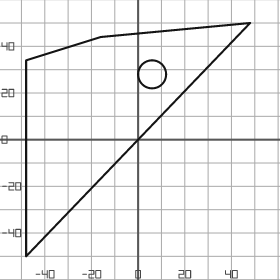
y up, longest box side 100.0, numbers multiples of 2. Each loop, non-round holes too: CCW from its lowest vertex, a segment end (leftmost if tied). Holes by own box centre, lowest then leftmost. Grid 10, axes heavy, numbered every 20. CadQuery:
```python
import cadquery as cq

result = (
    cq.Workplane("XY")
    .moveTo(-48.0, -50.0)
    .lineTo(48.0, 50.0)
    .lineTo(-16.0, 44.0)
    .lineTo(-48.0, 34.0)
    .close()
    .moveTo(6.0, 28.0)
    .circle(6.0)
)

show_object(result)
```